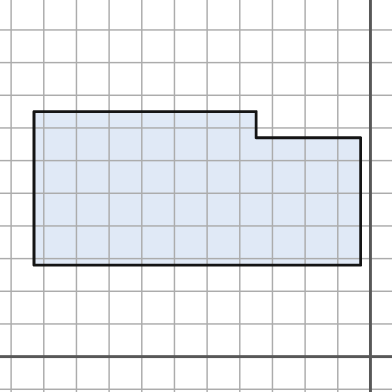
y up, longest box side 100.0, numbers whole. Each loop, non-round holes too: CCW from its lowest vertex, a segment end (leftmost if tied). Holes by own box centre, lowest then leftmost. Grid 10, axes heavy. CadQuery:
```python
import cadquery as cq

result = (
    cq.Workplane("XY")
    .moveTo(-103.0, 28.0)
    .lineTo(-3.0, 28.0)
    .lineTo(-3.0, 67.0)
    .lineTo(-35.0, 67.0)
    .lineTo(-35.0, 75.0)
    .lineTo(-103.0, 75.0)
    .close()
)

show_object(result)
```